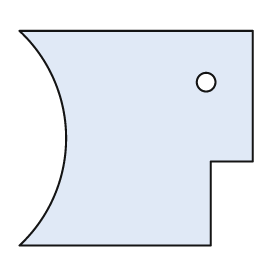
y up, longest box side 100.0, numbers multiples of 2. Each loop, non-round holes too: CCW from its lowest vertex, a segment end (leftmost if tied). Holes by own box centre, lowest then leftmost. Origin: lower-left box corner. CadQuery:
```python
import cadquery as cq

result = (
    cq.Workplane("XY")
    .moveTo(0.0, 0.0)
    .lineTo(82.0, 0.0)
    .lineTo(82.0, 36.0)
    .lineTo(100.0, 36.0)
    .lineTo(100.0, 92.0)
    .lineTo(0.0, 92.0)
    .threePointArc((20.0, 46.0), (0.0, 0.0))
    .close()
    .moveTo(80.0, 70.0)
    .circle(4.0)
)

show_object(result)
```